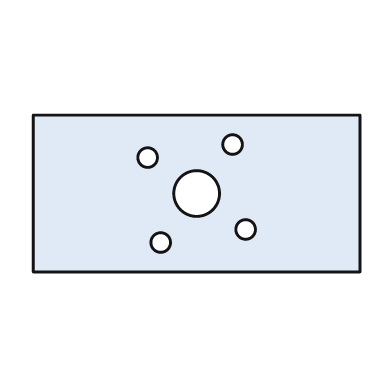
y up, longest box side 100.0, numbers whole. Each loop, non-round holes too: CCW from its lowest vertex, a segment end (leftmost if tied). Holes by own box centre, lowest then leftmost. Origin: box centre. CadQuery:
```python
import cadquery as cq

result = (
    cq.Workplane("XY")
    .moveTo(-50.0, -24.0)
    .lineTo(50.0, -24.0)
    .lineTo(50.0, 24.0)
    .lineTo(-50.0, 24.0)
    .close()
    .moveTo(-11.0, -15.0)
    .circle(3.0)
    .moveTo(15.0, -11.0)
    .circle(3.0)
    .moveTo(0.0, 0.0)
    .circle(7.0)
    .moveTo(-15.0, 11.0)
    .circle(3.0)
    .moveTo(11.0, 15.0)
    .circle(3.0)
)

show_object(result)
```